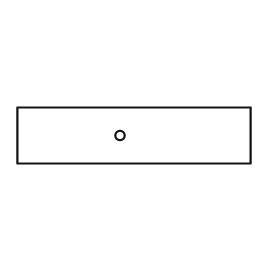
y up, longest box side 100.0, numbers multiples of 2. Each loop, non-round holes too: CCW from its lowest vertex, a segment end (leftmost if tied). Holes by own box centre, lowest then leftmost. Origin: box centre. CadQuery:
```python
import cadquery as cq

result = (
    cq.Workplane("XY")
    .moveTo(-50.0, -12.0)
    .lineTo(50.0, -12.0)
    .lineTo(50.0, 12.0)
    .lineTo(-50.0, 12.0)
    .close()
    .moveTo(-6.0, 0.0)
    .circle(2.0)
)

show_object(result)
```